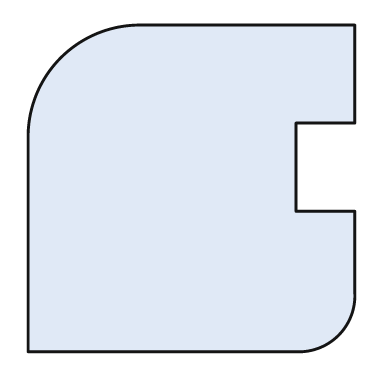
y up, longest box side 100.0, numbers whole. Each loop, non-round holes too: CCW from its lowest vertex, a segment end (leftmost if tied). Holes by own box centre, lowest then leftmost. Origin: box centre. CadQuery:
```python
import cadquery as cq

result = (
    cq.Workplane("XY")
    .moveTo(-50.0, -50.0)
    .lineTo(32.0, -50.0)
    .threePointArc((45.0, -45.0), (50.0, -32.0))
    .lineTo(50.0, -7.0)
    .lineTo(32.0, -7.0)
    .lineTo(32.0, 20.0)
    .lineTo(50.0, 20.0)
    .lineTo(50.0, 50.0)
    .lineTo(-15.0, 50.0)
    .threePointArc((-40.0, 40.0), (-50.0, 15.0))
    .close()
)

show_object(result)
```